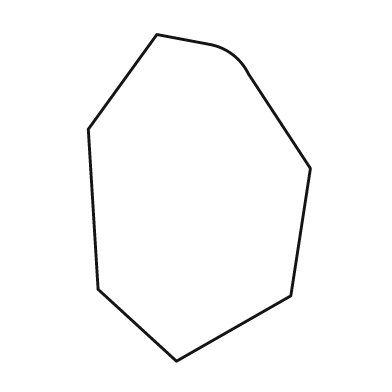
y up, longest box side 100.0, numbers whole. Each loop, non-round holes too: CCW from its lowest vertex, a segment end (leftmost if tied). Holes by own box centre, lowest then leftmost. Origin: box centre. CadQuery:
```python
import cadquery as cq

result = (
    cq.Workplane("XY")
    .moveTo(-7.0, -50.0)
    .lineTo(28.0, -30.0)
    .lineTo(34.0, 9.0)
    .lineTo(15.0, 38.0)
    .threePointArc((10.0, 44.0), (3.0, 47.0))
    .lineTo(-13.0, 50.0)
    .lineTo(-34.0, 21.0)
    .lineTo(-31.0, -28.0)
    .close()
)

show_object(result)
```